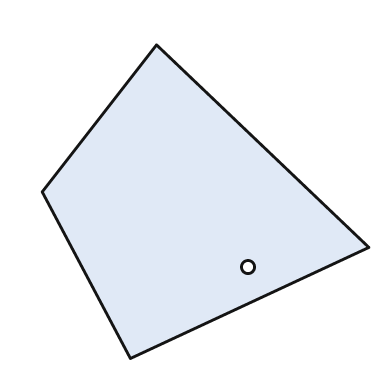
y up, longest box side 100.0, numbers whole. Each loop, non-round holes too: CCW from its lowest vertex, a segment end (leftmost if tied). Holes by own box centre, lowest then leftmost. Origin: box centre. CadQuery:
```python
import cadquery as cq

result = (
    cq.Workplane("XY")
    .moveTo(-23.0, -48.0)
    .lineTo(50.0, -14.0)
    .lineTo(-15.0, 48.0)
    .lineTo(-50.0, 3.0)
    .close()
    .moveTo(13.0, -20.0)
    .circle(2.0)
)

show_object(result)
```